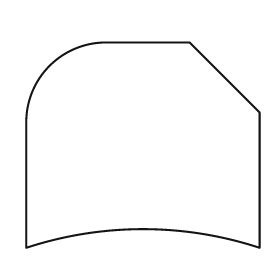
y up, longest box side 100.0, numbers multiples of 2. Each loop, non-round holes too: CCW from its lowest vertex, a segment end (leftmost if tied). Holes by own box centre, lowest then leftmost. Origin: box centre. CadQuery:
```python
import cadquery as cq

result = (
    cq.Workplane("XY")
    .moveTo(-50.0, -44.0)
    .threePointArc((0.0, -36.0), (50.0, -44.0))
    .lineTo(50.0, 14.0)
    .lineTo(20.0, 44.0)
    .lineTo(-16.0, 44.0)
    .threePointArc((-40.0, 34.0), (-50.0, 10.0))
    .close()
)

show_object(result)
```